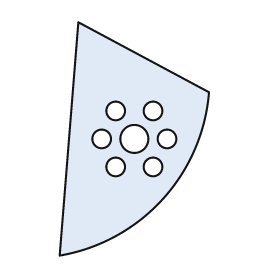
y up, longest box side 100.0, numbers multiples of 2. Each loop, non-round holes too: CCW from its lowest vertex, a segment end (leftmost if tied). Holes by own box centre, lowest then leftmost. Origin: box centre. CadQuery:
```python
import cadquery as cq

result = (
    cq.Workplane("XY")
    .moveTo(-32.0, -50.0)
    .threePointArc((12.0, -26.0), (32.0, 20.0))
    .lineTo(-24.0, 50.0)
    .close()
    .moveTo(-8.0, -12.0)
    .circle(4.0)
    .moveTo(8.0, -12.0)
    .circle(4.0)
    .moveTo(-14.0, 0.0)
    .circle(4.0)
    .moveTo(0.0, 0.0)
    .circle(6.0)
    .moveTo(14.0, 0.0)
    .circle(4.0)
    .moveTo(-8.0, 12.0)
    .circle(4.0)
    .moveTo(8.0, 12.0)
    .circle(4.0)
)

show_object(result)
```